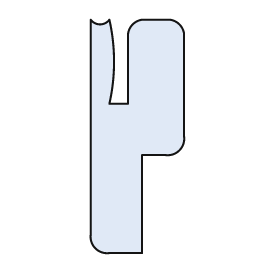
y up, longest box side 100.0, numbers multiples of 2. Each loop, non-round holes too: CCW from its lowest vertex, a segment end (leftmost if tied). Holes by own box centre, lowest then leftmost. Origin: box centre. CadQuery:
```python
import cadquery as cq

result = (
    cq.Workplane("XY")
    .moveTo(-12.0, -50.0)
    .lineTo(2.0, -50.0)
    .lineTo(2.0, -8.0)
    .lineTo(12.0, -8.0)
    .threePointArc((18.0, -6.0), (20.0, 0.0))
    .lineTo(20.0, 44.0)
    .threePointArc((18.0, 48.0), (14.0, 50.0))
    .lineTo(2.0, 50.0)
    .threePointArc((-2.0, 48.0), (-4.0, 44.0))
    .lineTo(-4.0, 14.0)
    .lineTo(-12.0, 14.0)
    .threePointArc((-10.0, 32.0), (-12.0, 50.0))
    .threePointArc((-16.0, 48.0), (-20.0, 50.0))
    .lineTo(-20.0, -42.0)
    .threePointArc((-18.0, -48.0), (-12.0, -50.0))
    .close()
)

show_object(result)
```